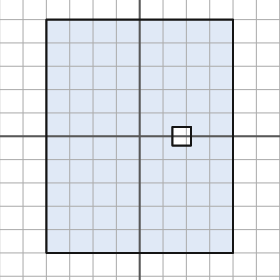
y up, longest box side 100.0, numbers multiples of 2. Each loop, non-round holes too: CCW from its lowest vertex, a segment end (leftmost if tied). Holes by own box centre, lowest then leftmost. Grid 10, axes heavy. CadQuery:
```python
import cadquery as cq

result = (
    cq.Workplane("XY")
    .moveTo(-40.0, -50.0)
    .lineTo(40.0, -50.0)
    .lineTo(40.0, 50.0)
    .lineTo(-40.0, 50.0)
    .close()
    .moveTo(14.0, -4.0)
    .lineTo(22.0, -4.0)
    .lineTo(22.0, 4.0)
    .lineTo(14.0, 4.0)
    .close()
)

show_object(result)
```